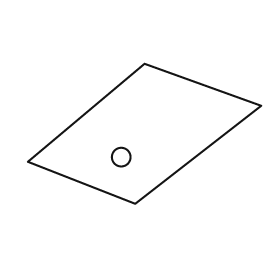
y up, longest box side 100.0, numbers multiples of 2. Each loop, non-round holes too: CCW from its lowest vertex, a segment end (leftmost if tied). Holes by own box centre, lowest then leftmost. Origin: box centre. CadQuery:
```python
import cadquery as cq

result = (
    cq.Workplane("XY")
    .moveTo(-4.0, -30.0)
    .lineTo(50.0, 12.0)
    .lineTo(0.0, 30.0)
    .lineTo(-50.0, -12.0)
    .close()
    .moveTo(-10.0, -10.0)
    .circle(4.0)
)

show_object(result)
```